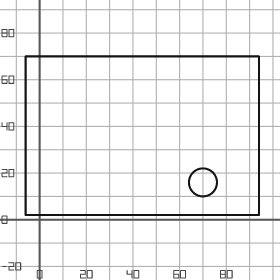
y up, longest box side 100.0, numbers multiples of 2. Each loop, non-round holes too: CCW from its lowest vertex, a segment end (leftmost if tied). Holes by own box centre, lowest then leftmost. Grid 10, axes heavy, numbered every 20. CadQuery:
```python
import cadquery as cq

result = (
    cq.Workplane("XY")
    .moveTo(-6.0, 2.0)
    .lineTo(94.0, 2.0)
    .lineTo(94.0, 70.0)
    .lineTo(-6.0, 70.0)
    .close()
    .moveTo(70.0, 16.0)
    .circle(6.0)
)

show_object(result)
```